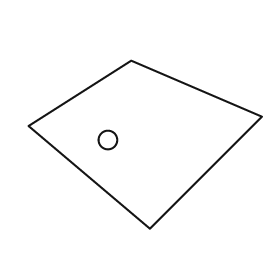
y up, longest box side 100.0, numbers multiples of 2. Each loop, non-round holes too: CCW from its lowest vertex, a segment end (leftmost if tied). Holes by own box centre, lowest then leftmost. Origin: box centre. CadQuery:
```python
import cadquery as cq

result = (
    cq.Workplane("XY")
    .moveTo(2.0, -36.0)
    .lineTo(50.0, 12.0)
    .lineTo(-6.0, 36.0)
    .lineTo(-50.0, 8.0)
    .close()
    .moveTo(-16.0, 2.0)
    .circle(4.0)
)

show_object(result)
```